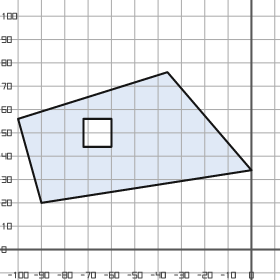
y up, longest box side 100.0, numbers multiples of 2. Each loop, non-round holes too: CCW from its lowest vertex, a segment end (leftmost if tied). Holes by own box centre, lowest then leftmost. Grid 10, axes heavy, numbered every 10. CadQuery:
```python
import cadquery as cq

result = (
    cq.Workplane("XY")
    .moveTo(-90.0, 20.0)
    .lineTo(0.0, 34.0)
    .lineTo(-36.0, 76.0)
    .lineTo(-100.0, 56.0)
    .close()
    .moveTo(-72.0, 44.0)
    .lineTo(-60.0, 44.0)
    .lineTo(-60.0, 56.0)
    .lineTo(-72.0, 56.0)
    .close()
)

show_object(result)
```